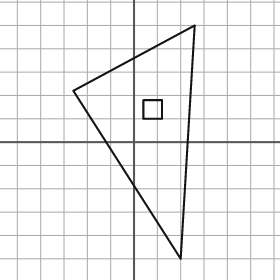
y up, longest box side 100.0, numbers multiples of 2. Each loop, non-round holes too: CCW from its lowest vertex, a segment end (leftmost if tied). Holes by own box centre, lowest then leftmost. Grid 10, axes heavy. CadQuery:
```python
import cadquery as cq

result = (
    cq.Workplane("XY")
    .moveTo(20.0, -50.0)
    .lineTo(26.0, 50.0)
    .lineTo(-26.0, 22.0)
    .close()
    .moveTo(4.0, 10.0)
    .lineTo(12.0, 10.0)
    .lineTo(12.0, 18.0)
    .lineTo(4.0, 18.0)
    .close()
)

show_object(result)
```